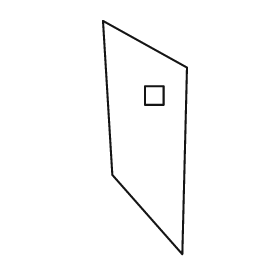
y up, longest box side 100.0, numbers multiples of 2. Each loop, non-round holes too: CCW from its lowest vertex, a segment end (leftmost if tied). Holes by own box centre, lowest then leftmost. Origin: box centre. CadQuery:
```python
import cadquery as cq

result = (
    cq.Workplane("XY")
    .moveTo(16.0, -50.0)
    .lineTo(18.0, 30.0)
    .lineTo(-18.0, 50.0)
    .lineTo(-14.0, -16.0)
    .close()
    .moveTo(0.0, 14.0)
    .lineTo(8.0, 14.0)
    .lineTo(8.0, 22.0)
    .lineTo(0.0, 22.0)
    .close()
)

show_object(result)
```